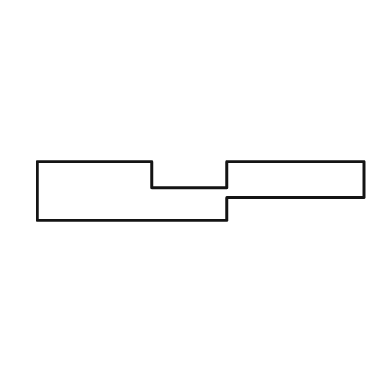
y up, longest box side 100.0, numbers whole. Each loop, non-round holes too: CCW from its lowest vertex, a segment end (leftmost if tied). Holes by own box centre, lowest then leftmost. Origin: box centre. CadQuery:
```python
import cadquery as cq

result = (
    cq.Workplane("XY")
    .moveTo(-50.0, -9.0)
    .lineTo(8.0, -9.0)
    .lineTo(8.0, -2.0)
    .lineTo(50.0, -2.0)
    .lineTo(50.0, 9.0)
    .lineTo(8.0, 9.0)
    .lineTo(8.0, 1.0)
    .lineTo(-15.0, 1.0)
    .lineTo(-15.0, 9.0)
    .lineTo(-50.0, 9.0)
    .close()
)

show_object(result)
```